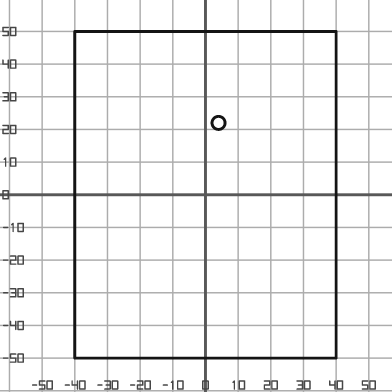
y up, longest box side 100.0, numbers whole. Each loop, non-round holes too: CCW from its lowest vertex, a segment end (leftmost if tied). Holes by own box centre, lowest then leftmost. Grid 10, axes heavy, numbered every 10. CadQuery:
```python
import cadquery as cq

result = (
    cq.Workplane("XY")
    .moveTo(-40.0, -50.0)
    .lineTo(40.0, -50.0)
    .lineTo(40.0, 50.0)
    .lineTo(-40.0, 50.0)
    .close()
    .moveTo(4.0, 22.0)
    .circle(2.0)
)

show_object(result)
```